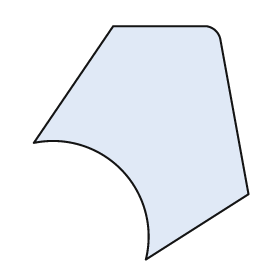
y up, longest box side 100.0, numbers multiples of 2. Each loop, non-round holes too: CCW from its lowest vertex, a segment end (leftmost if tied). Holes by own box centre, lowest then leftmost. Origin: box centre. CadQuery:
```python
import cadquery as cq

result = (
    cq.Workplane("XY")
    .moveTo(2.0, -50.0)
    .lineTo(46.0, -22.0)
    .lineTo(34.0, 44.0)
    .threePointArc((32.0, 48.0), (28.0, 50.0))
    .lineTo(-12.0, 50.0)
    .lineTo(-46.0, 0.0)
    .threePointArc((-8.0, -12.0), (2.0, -50.0))
    .close()
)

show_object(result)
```